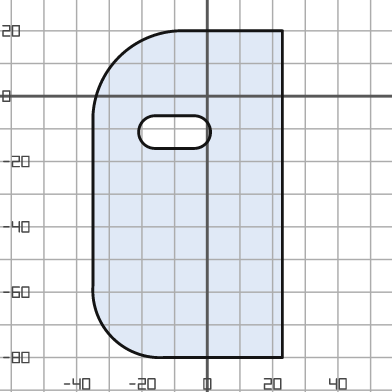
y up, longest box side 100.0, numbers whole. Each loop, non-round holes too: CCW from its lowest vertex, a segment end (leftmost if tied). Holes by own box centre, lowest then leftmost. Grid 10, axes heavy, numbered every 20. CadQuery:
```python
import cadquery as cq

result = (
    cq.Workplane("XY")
    .moveTo(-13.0, -80.0)
    .lineTo(23.0, -80.0)
    .lineTo(23.0, 20.0)
    .lineTo(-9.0, 20.0)
    .threePointArc((-27.0, 12.0), (-35.0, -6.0))
    .lineTo(-35.0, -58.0)
    .threePointArc((-29.0, -74.0), (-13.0, -80.0))
    .close()
    .moveTo(-16.0, -16.0)
    .lineTo(-4.0, -16.0)
    .threePointArc((1.0, -11.0), (-4.0, -6.0))
    .lineTo(-16.0, -6.0)
    .threePointArc((-21.0, -11.0), (-16.0, -16.0))
    .close()
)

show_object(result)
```